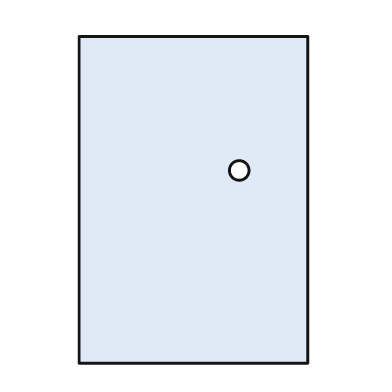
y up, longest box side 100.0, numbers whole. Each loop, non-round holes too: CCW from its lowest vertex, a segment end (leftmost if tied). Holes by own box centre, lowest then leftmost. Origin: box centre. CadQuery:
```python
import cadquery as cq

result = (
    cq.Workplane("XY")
    .moveTo(-35.0, -50.0)
    .lineTo(35.0, -50.0)
    .lineTo(35.0, 50.0)
    .lineTo(-35.0, 50.0)
    .close()
    .moveTo(14.0, 9.0)
    .circle(3.0)
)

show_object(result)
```